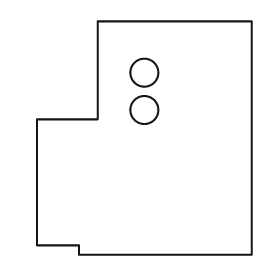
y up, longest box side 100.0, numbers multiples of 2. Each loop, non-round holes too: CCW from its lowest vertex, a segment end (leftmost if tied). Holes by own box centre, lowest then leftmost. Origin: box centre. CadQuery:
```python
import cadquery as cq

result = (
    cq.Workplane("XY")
    .moveTo(-28.0, -50.0)
    .lineTo(46.0, -50.0)
    .lineTo(46.0, 50.0)
    .lineTo(-20.0, 50.0)
    .lineTo(-20.0, 8.0)
    .lineTo(-46.0, 8.0)
    .lineTo(-46.0, -46.0)
    .lineTo(-28.0, -46.0)
    .close()
    .moveTo(0.0, 12.0)
    .circle(6.0)
    .moveTo(0.0, 28.0)
    .circle(6.0)
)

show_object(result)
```